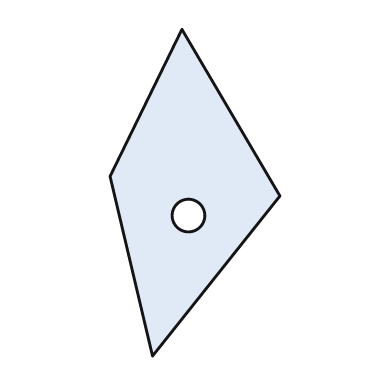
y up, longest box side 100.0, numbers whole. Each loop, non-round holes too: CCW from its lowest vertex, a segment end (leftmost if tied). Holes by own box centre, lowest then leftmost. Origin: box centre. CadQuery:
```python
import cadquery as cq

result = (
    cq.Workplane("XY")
    .moveTo(-13.0, -50.0)
    .lineTo(26.0, -1.0)
    .lineTo(-4.0, 50.0)
    .lineTo(-26.0, 5.0)
    .close()
    .moveTo(-2.0, -7.0)
    .circle(5.0)
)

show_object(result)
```